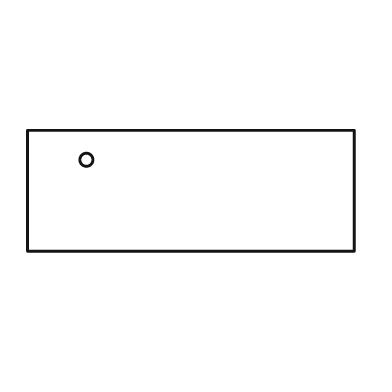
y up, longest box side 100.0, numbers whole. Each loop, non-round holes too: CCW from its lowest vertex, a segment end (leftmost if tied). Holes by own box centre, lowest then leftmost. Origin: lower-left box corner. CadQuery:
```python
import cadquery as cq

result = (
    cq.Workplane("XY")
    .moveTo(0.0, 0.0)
    .lineTo(100.0, 0.0)
    .lineTo(100.0, 37.0)
    .lineTo(0.0, 37.0)
    .close()
    .moveTo(18.0, 28.0)
    .circle(2.0)
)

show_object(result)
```